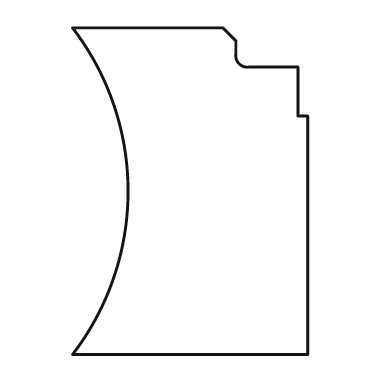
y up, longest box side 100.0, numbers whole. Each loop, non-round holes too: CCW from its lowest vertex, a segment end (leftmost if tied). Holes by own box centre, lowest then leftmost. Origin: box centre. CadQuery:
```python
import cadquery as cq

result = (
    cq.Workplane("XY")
    .moveTo(-36.0, -50.0)
    .lineTo(36.0, -50.0)
    .lineTo(36.0, 23.0)
    .lineTo(33.0, 23.0)
    .lineTo(33.0, 38.0)
    .lineTo(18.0, 38.0)
    .threePointArc((15.0, 39.0), (14.0, 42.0))
    .lineTo(14.0, 46.0)
    .lineTo(10.0, 50.0)
    .lineTo(-36.0, 50.0)
    .threePointArc((-19.0, 0.0), (-36.0, -50.0))
    .close()
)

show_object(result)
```